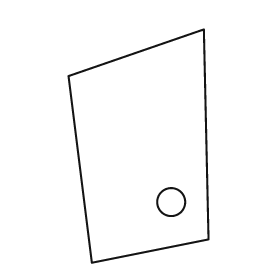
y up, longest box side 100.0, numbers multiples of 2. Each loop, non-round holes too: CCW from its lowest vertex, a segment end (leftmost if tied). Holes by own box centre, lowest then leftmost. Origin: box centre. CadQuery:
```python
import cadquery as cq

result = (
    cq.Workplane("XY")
    .moveTo(-20.0, -50.0)
    .lineTo(30.0, -40.0)
    .lineTo(28.0, 50.0)
    .lineTo(-30.0, 30.0)
    .close()
    .moveTo(14.0, -24.0)
    .circle(6.0)
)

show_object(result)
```